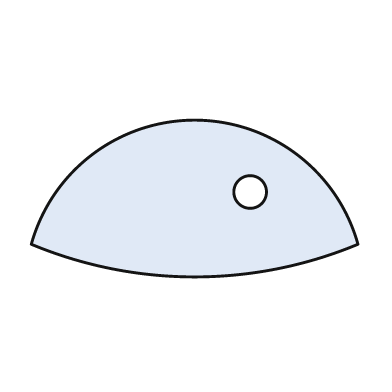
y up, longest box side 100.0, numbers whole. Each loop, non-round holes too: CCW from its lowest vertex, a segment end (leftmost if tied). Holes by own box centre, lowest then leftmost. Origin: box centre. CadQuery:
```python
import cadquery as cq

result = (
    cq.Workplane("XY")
    .moveTo(-50.0, -14.0)
    .threePointArc((0.0, -24.0), (50.0, -14.0))
    .threePointArc((0.0, 24.0), (-50.0, -14.0))
    .close()
    .moveTo(17.0, 2.0)
    .circle(5.0)
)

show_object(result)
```